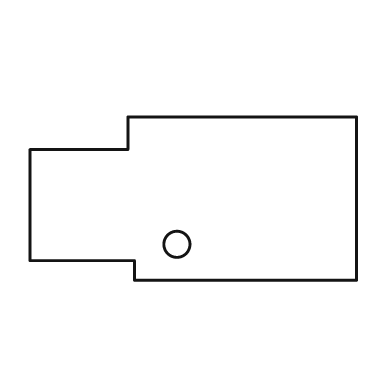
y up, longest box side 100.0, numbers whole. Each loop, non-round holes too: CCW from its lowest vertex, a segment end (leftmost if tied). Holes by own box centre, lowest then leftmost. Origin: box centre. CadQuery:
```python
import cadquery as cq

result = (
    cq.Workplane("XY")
    .moveTo(-18.0, -25.0)
    .lineTo(50.0, -25.0)
    .lineTo(50.0, 25.0)
    .lineTo(-20.0, 25.0)
    .lineTo(-20.0, 15.0)
    .lineTo(-50.0, 15.0)
    .lineTo(-50.0, -19.0)
    .lineTo(-18.0, -19.0)
    .close()
    .moveTo(-5.0, -14.0)
    .circle(4.0)
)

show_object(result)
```